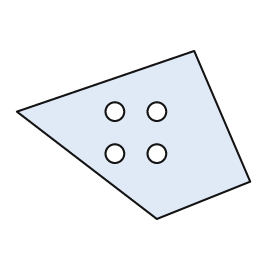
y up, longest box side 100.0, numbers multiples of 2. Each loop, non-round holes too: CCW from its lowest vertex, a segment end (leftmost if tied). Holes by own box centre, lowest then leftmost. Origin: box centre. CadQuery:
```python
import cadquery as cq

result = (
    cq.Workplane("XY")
    .moveTo(10.0, -36.0)
    .lineTo(50.0, -20.0)
    .lineTo(26.0, 36.0)
    .lineTo(-50.0, 10.0)
    .close()
    .moveTo(-8.0, -8.0)
    .circle(4.0)
    .moveTo(10.0, -8.0)
    .circle(4.0)
    .moveTo(-8.0, 10.0)
    .circle(4.0)
    .moveTo(10.0, 10.0)
    .circle(4.0)
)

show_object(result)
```